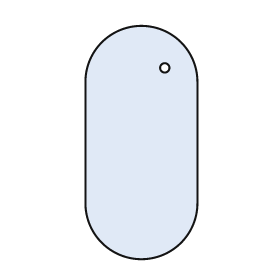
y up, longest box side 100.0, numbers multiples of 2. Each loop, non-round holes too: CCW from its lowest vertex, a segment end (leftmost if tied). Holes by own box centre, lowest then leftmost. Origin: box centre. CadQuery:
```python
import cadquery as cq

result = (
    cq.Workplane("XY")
    .moveTo(-24.0, -26.0)
    .threePointArc((0.0, -50.0), (24.0, -26.0))
    .lineTo(24.0, 26.0)
    .threePointArc((0.0, 50.0), (-24.0, 26.0))
    .close()
    .moveTo(10.0, 32.0)
    .circle(2.0)
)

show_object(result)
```